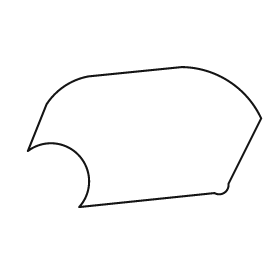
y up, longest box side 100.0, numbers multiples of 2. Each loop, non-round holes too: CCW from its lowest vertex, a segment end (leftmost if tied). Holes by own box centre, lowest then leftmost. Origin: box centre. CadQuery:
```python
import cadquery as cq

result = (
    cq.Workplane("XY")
    .moveTo(-28.0, -30.0)
    .lineTo(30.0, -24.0)
    .threePointArc((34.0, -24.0), (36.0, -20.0))
    .lineTo(50.0, 8.0)
    .threePointArc((36.0, 24.0), (16.0, 30.0))
    .lineTo(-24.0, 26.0)
    .threePointArc((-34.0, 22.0), (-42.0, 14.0))
    .lineTo(-50.0, -6.0)
    .threePointArc((-28.0, -8.0), (-28.0, -30.0))
    .close()
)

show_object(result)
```